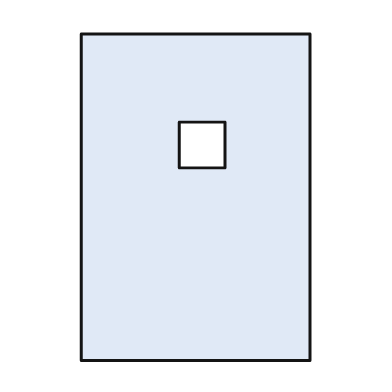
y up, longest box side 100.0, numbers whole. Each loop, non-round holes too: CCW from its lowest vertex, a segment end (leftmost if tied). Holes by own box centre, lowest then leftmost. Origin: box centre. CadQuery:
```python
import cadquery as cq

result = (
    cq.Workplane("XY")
    .moveTo(-35.0, -50.0)
    .lineTo(35.0, -50.0)
    .lineTo(35.0, 50.0)
    .lineTo(-35.0, 50.0)
    .close()
    .moveTo(-5.0, 9.0)
    .lineTo(9.0, 9.0)
    .lineTo(9.0, 23.0)
    .lineTo(-5.0, 23.0)
    .close()
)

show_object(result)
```